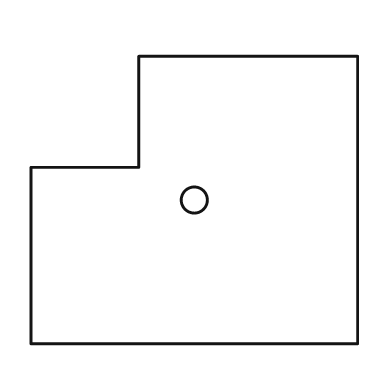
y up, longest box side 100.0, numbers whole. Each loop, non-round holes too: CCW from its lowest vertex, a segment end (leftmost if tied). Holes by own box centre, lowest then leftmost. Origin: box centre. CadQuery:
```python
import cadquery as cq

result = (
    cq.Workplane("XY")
    .moveTo(-50.0, -44.0)
    .lineTo(50.0, -44.0)
    .lineTo(50.0, 44.0)
    .lineTo(-17.0, 44.0)
    .lineTo(-17.0, 10.0)
    .lineTo(-50.0, 10.0)
    .close()
    .moveTo(0.0, 0.0)
    .circle(4.0)
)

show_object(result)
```